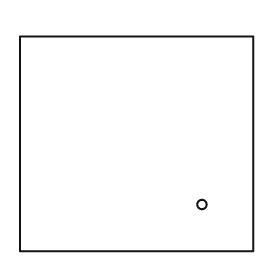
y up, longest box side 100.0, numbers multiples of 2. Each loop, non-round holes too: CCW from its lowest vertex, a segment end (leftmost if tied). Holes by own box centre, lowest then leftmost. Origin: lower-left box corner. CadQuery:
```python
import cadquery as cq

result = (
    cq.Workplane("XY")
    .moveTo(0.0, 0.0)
    .lineTo(100.0, 0.0)
    .lineTo(100.0, 92.0)
    .lineTo(0.0, 92.0)
    .close()
    .moveTo(78.0, 20.0)
    .circle(2.0)
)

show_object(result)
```